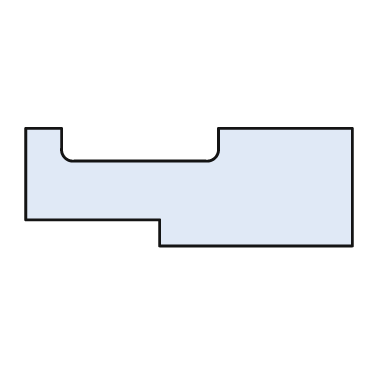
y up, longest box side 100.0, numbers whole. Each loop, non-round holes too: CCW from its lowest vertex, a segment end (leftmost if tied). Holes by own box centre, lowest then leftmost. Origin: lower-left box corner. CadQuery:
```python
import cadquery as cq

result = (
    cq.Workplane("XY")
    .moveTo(41.0, 0.0)
    .lineTo(100.0, 0.0)
    .lineTo(100.0, 36.0)
    .lineTo(59.0, 36.0)
    .lineTo(59.0, 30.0)
    .threePointArc((58.0, 27.0), (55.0, 26.0))
    .lineTo(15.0, 26.0)
    .threePointArc((12.0, 27.0), (11.0, 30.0))
    .lineTo(11.0, 36.0)
    .lineTo(0.0, 36.0)
    .lineTo(0.0, 8.0)
    .lineTo(41.0, 8.0)
    .close()
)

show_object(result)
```